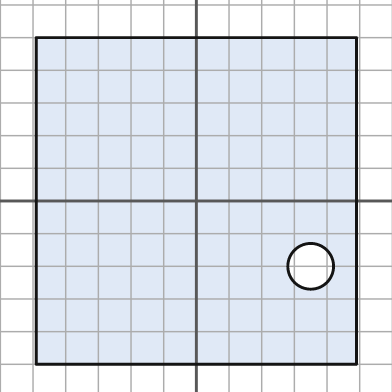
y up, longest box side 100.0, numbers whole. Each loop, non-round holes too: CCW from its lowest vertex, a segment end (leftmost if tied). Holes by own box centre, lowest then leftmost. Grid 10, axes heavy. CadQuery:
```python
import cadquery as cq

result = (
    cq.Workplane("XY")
    .moveTo(-49.0, -50.0)
    .lineTo(49.0, -50.0)
    .lineTo(49.0, 50.0)
    .lineTo(-49.0, 50.0)
    .close()
    .moveTo(35.0, -20.0)
    .circle(7.0)
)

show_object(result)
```